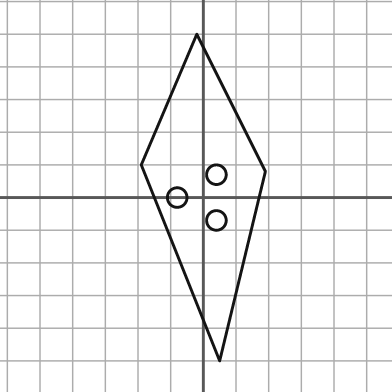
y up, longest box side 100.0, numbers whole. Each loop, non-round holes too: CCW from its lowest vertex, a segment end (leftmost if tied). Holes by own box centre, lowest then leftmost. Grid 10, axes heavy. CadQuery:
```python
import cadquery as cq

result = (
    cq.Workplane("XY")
    .moveTo(5.0, -50.0)
    .lineTo(19.0, 8.0)
    .lineTo(-2.0, 50.0)
    .lineTo(-19.0, 10.0)
    .close()
    .moveTo(4.0, -7.0)
    .circle(3.0)
    .moveTo(-8.0, 0.0)
    .circle(3.0)
    .moveTo(4.0, 7.0)
    .circle(3.0)
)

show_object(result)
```